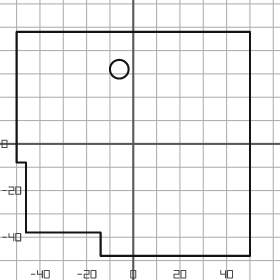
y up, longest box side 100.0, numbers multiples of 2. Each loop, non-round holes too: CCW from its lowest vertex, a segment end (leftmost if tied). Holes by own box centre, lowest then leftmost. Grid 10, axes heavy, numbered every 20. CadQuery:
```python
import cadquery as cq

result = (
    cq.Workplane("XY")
    .moveTo(-14.0, -48.0)
    .lineTo(50.0, -48.0)
    .lineTo(50.0, 48.0)
    .lineTo(-50.0, 48.0)
    .lineTo(-50.0, -8.0)
    .lineTo(-46.0, -8.0)
    .lineTo(-46.0, -38.0)
    .lineTo(-14.0, -38.0)
    .close()
    .moveTo(-6.0, 32.0)
    .circle(4.0)
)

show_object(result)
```